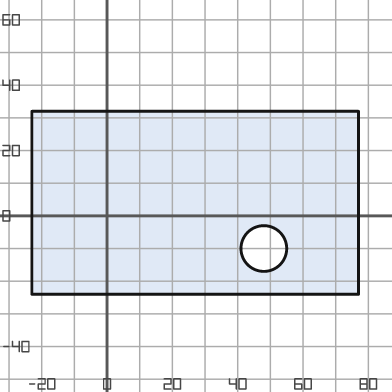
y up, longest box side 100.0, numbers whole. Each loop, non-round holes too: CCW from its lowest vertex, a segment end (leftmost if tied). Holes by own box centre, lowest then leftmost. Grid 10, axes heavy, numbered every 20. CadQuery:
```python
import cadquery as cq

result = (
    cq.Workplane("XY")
    .moveTo(-23.0, -24.0)
    .lineTo(77.0, -24.0)
    .lineTo(77.0, 32.0)
    .lineTo(-23.0, 32.0)
    .close()
    .moveTo(48.0, -10.0)
    .circle(7.0)
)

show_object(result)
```